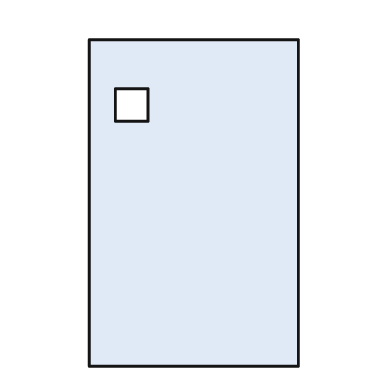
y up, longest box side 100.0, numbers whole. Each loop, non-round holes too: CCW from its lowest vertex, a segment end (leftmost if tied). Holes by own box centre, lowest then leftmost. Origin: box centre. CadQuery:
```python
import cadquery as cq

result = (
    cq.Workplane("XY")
    .moveTo(-32.0, -50.0)
    .lineTo(32.0, -50.0)
    .lineTo(32.0, 50.0)
    .lineTo(-32.0, 50.0)
    .close()
    .moveTo(-24.0, 25.0)
    .lineTo(-14.0, 25.0)
    .lineTo(-14.0, 35.0)
    .lineTo(-24.0, 35.0)
    .close()
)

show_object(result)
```